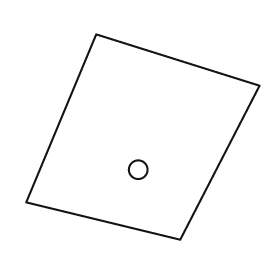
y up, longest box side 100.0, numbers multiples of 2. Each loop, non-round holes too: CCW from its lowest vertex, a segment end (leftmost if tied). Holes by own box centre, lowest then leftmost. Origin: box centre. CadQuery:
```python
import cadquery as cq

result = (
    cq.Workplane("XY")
    .moveTo(16.0, -44.0)
    .lineTo(50.0, 22.0)
    .lineTo(-20.0, 44.0)
    .lineTo(-50.0, -28.0)
    .close()
    .moveTo(-2.0, -14.0)
    .circle(4.0)
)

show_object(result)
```